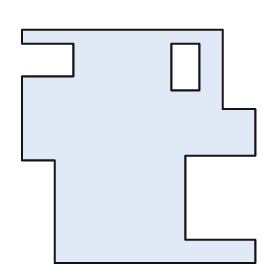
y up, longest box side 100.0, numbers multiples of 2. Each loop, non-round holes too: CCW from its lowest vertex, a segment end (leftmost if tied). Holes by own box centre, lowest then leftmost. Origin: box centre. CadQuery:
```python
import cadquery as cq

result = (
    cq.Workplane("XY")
    .moveTo(-36.0, -50.0)
    .lineTo(50.0, -50.0)
    .lineTo(50.0, -40.0)
    .lineTo(20.0, -40.0)
    .lineTo(20.0, -4.0)
    .lineTo(50.0, -4.0)
    .lineTo(50.0, 16.0)
    .lineTo(36.0, 16.0)
    .lineTo(36.0, 50.0)
    .lineTo(-50.0, 50.0)
    .lineTo(-50.0, 44.0)
    .lineTo(-28.0, 44.0)
    .lineTo(-28.0, 30.0)
    .lineTo(-50.0, 30.0)
    .lineTo(-50.0, -6.0)
    .lineTo(-36.0, -6.0)
    .close()
    .moveTo(14.0, 24.0)
    .lineTo(26.0, 24.0)
    .lineTo(26.0, 44.0)
    .lineTo(14.0, 44.0)
    .close()
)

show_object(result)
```